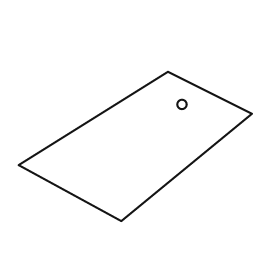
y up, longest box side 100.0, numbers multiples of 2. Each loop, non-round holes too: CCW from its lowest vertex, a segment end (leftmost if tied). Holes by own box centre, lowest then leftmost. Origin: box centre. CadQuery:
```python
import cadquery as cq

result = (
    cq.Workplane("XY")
    .moveTo(-6.0, -32.0)
    .lineTo(50.0, 14.0)
    .lineTo(14.0, 32.0)
    .lineTo(-50.0, -8.0)
    .close()
    .moveTo(20.0, 18.0)
    .circle(2.0)
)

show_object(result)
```